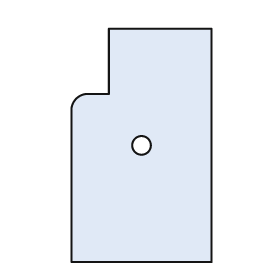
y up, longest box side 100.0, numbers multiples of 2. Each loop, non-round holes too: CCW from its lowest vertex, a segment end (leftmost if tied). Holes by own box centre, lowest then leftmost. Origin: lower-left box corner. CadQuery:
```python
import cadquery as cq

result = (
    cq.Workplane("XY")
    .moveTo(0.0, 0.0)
    .lineTo(60.0, 0.0)
    .lineTo(60.0, 100.0)
    .lineTo(16.0, 100.0)
    .lineTo(16.0, 72.0)
    .lineTo(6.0, 72.0)
    .threePointArc((2.0, 70.0), (0.0, 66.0))
    .close()
    .moveTo(30.0, 50.0)
    .circle(4.0)
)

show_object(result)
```